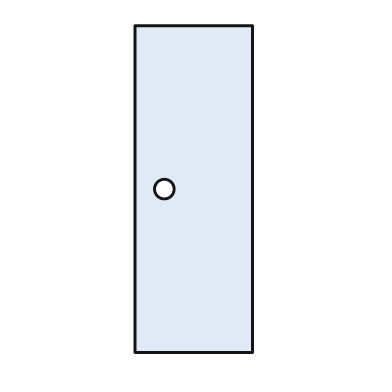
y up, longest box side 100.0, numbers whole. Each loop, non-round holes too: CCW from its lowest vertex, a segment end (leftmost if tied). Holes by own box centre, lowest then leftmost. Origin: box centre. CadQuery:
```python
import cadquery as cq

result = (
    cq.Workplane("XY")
    .moveTo(-18.0, -50.0)
    .lineTo(18.0, -50.0)
    .lineTo(18.0, 50.0)
    .lineTo(-18.0, 50.0)
    .close()
    .moveTo(-9.0, 0.0)
    .circle(3.0)
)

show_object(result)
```